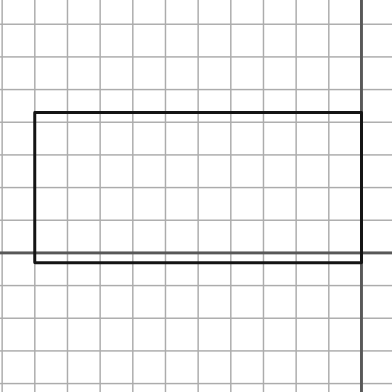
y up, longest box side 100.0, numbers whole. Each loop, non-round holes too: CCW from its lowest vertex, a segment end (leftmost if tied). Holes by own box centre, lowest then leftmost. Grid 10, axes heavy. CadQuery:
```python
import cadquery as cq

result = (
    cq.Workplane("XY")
    .moveTo(-100.0, -3.0)
    .lineTo(0.0, -3.0)
    .lineTo(0.0, 43.0)
    .lineTo(-100.0, 43.0)
    .close()
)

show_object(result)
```